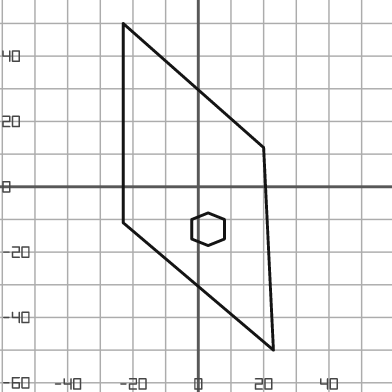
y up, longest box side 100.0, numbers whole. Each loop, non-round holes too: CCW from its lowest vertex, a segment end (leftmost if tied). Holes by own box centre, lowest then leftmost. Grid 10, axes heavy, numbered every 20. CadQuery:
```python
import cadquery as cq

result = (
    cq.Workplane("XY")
    .moveTo(23.0, -50.0)
    .lineTo(20.0, 12.0)
    .lineTo(-23.0, 50.0)
    .lineTo(-23.0, -11.0)
    .close()
    .moveTo(3.0, -18.0)
    .lineTo(8.0, -16.0)
    .lineTo(8.0, -10.0)
    .lineTo(3.0, -8.0)
    .lineTo(-2.0, -10.0)
    .lineTo(-2.0, -16.0)
    .close()
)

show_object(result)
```